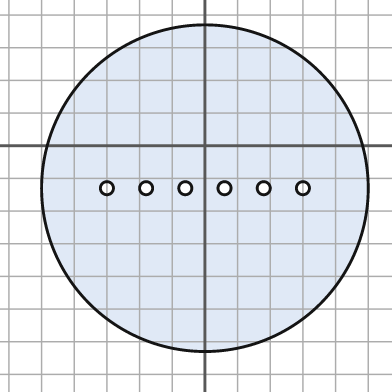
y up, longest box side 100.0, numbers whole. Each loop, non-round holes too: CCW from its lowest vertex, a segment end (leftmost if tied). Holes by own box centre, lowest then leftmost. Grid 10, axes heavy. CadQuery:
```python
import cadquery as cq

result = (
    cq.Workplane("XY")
    .moveTo(0.0, -13.0)
    .circle(50.0)
    .moveTo(-30.0, -13.0)
    .circle(2.0)
    .moveTo(-18.0, -13.0)
    .circle(2.0)
    .moveTo(-6.0, -13.0)
    .circle(2.0)
    .moveTo(6.0, -13.0)
    .circle(2.0)
    .moveTo(18.0, -13.0)
    .circle(2.0)
    .moveTo(30.0, -13.0)
    .circle(2.0)
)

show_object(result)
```